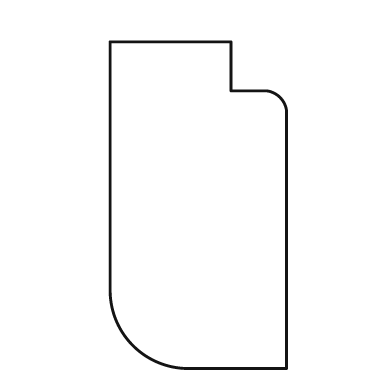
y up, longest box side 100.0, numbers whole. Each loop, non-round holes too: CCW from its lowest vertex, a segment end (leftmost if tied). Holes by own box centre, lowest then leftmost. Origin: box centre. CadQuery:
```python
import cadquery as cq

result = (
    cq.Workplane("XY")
    .moveTo(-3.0, -50.0)
    .lineTo(27.0, -50.0)
    .lineTo(27.0, 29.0)
    .threePointArc((25.0, 33.0), (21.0, 35.0))
    .lineTo(10.0, 35.0)
    .lineTo(10.0, 50.0)
    .lineTo(-27.0, 50.0)
    .lineTo(-27.0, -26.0)
    .threePointArc((-20.0, -43.0), (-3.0, -50.0))
    .close()
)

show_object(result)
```